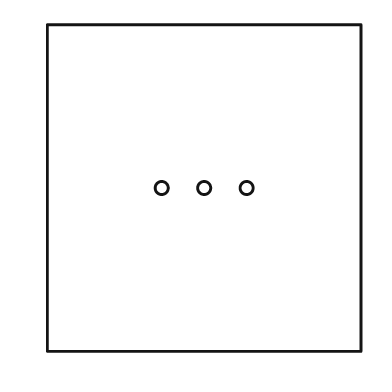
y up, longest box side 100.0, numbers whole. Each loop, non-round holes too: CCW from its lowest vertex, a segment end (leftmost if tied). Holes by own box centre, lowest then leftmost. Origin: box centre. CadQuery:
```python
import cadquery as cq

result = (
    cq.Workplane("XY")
    .moveTo(-48.0, -50.0)
    .lineTo(48.0, -50.0)
    .lineTo(48.0, 50.0)
    .lineTo(-48.0, 50.0)
    .close()
    .moveTo(-13.0, 0.0)
    .circle(2.0)
    .moveTo(0.0, 0.0)
    .circle(2.0)
    .moveTo(13.0, 0.0)
    .circle(2.0)
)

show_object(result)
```